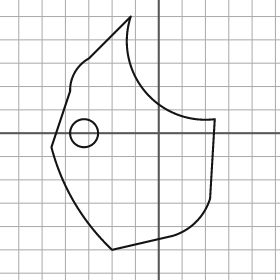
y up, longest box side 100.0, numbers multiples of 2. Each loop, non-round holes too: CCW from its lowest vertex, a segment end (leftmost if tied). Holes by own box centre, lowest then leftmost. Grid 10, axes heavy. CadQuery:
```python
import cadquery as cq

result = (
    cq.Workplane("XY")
    .moveTo(-20.0, -50.0)
    .lineTo(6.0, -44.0)
    .threePointArc((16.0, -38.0), (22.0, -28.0))
    .lineTo(24.0, 6.0)
    .threePointArc((-6.0, 18.0), (-12.0, 50.0))
    .lineTo(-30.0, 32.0)
    .threePointArc((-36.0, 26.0), (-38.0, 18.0))
    .lineTo(-46.0, -6.0)
    .threePointArc((-36.0, -30.0), (-20.0, -50.0))
    .close()
    .moveTo(-32.0, 0.0)
    .circle(6.0)
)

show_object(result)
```